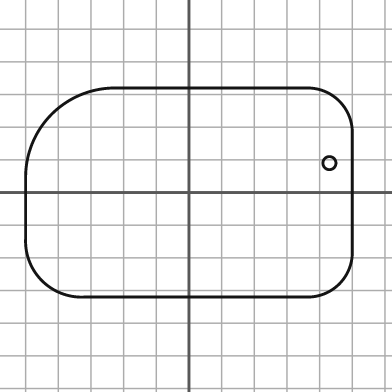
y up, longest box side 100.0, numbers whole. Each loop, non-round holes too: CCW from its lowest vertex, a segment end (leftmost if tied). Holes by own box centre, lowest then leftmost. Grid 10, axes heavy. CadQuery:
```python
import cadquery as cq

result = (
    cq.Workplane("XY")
    .moveTo(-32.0, -32.0)
    .lineTo(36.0, -32.0)
    .threePointArc((46.0, -28.0), (50.0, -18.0))
    .lineTo(50.0, 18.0)
    .threePointArc((46.0, 28.0), (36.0, 32.0))
    .lineTo(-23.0, 32.0)
    .threePointArc((-42.0, 24.0), (-50.0, 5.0))
    .lineTo(-50.0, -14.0)
    .threePointArc((-45.0, -27.0), (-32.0, -32.0))
    .close()
    .moveTo(43.0, 9.0)
    .circle(2.0)
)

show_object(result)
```